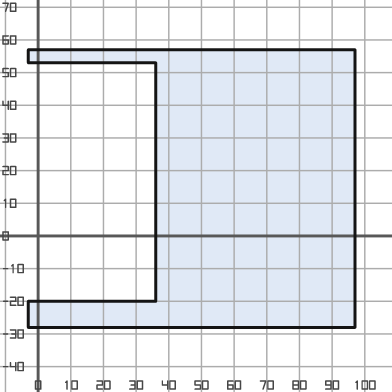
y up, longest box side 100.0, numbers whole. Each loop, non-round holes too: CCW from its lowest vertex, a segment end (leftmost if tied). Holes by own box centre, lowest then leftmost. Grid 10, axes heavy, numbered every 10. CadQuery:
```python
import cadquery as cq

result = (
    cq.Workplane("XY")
    .moveTo(-3.0, -28.0)
    .lineTo(97.0, -28.0)
    .lineTo(97.0, 57.0)
    .lineTo(-3.0, 57.0)
    .lineTo(-3.0, 53.0)
    .lineTo(36.0, 53.0)
    .lineTo(36.0, -20.0)
    .lineTo(-3.0, -20.0)
    .close()
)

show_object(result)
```